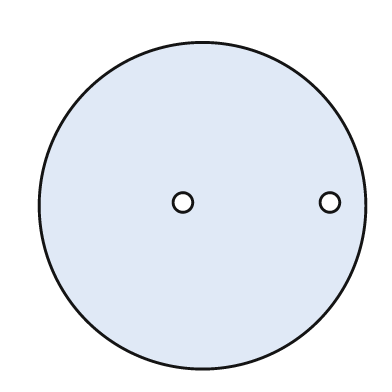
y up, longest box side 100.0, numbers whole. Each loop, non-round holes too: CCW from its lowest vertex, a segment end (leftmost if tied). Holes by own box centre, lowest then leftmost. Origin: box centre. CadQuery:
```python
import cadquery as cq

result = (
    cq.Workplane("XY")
    .moveTo(0.0, 0.0)
    .circle(50.0)
    .moveTo(-6.0, 1.0)
    .circle(3.0)
    .moveTo(39.0, 1.0)
    .circle(3.0)
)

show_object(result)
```